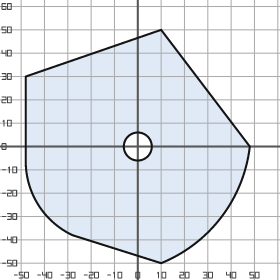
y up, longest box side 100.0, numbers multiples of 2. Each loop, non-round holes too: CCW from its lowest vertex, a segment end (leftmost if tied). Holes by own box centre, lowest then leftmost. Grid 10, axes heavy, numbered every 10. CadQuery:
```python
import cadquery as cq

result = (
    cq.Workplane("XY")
    .moveTo(10.0, -50.0)
    .threePointArc((36.0, -30.0), (48.0, 0.0))
    .lineTo(10.0, 50.0)
    .lineTo(-48.0, 30.0)
    .lineTo(-48.0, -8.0)
    .threePointArc((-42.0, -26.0), (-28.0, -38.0))
    .close()
    .moveTo(0.0, 0.0)
    .circle(6.0)
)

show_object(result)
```